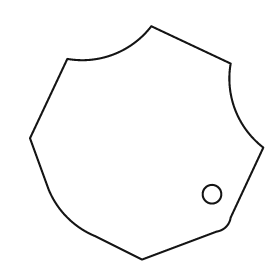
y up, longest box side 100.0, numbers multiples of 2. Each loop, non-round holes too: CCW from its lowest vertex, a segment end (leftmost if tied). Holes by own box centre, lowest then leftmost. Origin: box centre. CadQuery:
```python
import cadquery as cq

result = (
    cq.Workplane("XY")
    .moveTo(-2.0, -50.0)
    .lineTo(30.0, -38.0)
    .threePointArc((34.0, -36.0), (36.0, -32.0))
    .lineTo(50.0, -2.0)
    .threePointArc((38.0, 14.0), (36.0, 34.0))
    .lineTo(2.0, 50.0)
    .threePointArc((-14.0, 38.0), (-34.0, 36.0))
    .lineTo(-50.0, 2.0)
    .lineTo(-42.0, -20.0)
    .threePointArc((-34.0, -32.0), (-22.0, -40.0))
    .close()
    .moveTo(28.0, -22.0)
    .circle(4.0)
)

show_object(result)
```